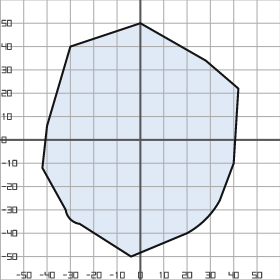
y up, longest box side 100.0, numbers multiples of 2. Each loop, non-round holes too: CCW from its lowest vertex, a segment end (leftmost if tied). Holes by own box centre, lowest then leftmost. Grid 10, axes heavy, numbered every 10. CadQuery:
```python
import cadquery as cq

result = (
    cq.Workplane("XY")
    .moveTo(-4.0, -50.0)
    .lineTo(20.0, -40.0)
    .threePointArc((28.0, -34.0), (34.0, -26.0))
    .lineTo(40.0, -10.0)
    .lineTo(42.0, 22.0)
    .lineTo(28.0, 34.0)
    .lineTo(0.0, 50.0)
    .lineTo(-30.0, 40.0)
    .lineTo(-40.0, 6.0)
    .lineTo(-42.0, -12.0)
    .lineTo(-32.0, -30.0)
    .threePointArc((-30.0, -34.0), (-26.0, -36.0))
    .close()
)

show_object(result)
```